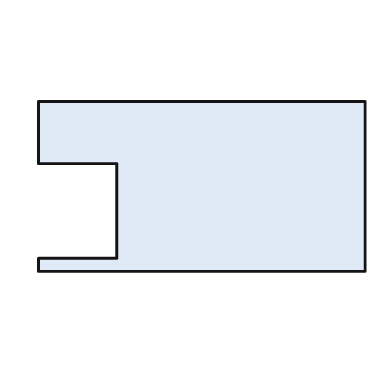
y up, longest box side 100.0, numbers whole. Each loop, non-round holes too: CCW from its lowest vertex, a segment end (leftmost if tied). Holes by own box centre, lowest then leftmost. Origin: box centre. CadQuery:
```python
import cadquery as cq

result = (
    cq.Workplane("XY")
    .moveTo(-50.0, -26.0)
    .lineTo(50.0, -26.0)
    .lineTo(50.0, 26.0)
    .lineTo(-50.0, 26.0)
    .lineTo(-50.0, 7.0)
    .lineTo(-26.0, 7.0)
    .lineTo(-26.0, -22.0)
    .lineTo(-50.0, -22.0)
    .close()
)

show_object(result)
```